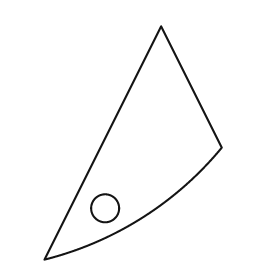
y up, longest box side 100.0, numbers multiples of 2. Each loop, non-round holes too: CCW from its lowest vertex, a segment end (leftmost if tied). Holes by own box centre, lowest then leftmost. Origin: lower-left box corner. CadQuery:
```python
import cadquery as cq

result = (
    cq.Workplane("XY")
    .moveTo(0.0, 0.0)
    .threePointArc((42.0, 18.0), (76.0, 48.0))
    .lineTo(50.0, 100.0)
    .close()
    .moveTo(26.0, 22.0)
    .circle(6.0)
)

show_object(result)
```